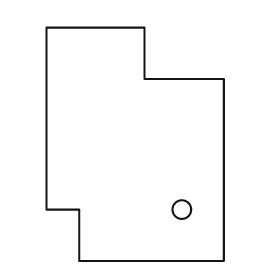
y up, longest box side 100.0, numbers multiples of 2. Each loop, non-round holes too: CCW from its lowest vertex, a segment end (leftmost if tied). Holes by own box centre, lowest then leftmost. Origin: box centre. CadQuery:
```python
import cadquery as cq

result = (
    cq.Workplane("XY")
    .moveTo(-24.0, -50.0)
    .lineTo(38.0, -50.0)
    .lineTo(38.0, 28.0)
    .lineTo(4.0, 28.0)
    .lineTo(4.0, 50.0)
    .lineTo(-38.0, 50.0)
    .lineTo(-38.0, -28.0)
    .lineTo(-24.0, -28.0)
    .close()
    .moveTo(20.0, -28.0)
    .circle(4.0)
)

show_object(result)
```